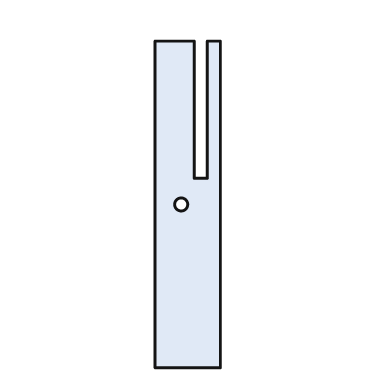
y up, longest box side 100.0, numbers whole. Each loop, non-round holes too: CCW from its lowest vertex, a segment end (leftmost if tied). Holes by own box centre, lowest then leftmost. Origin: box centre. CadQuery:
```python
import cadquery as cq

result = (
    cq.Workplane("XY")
    .moveTo(-10.0, -50.0)
    .lineTo(10.0, -50.0)
    .lineTo(10.0, 50.0)
    .lineTo(6.0, 50.0)
    .lineTo(6.0, 8.0)
    .lineTo(2.0, 8.0)
    .lineTo(2.0, 50.0)
    .lineTo(-10.0, 50.0)
    .close()
    .moveTo(-2.0, 0.0)
    .circle(2.0)
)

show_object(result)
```